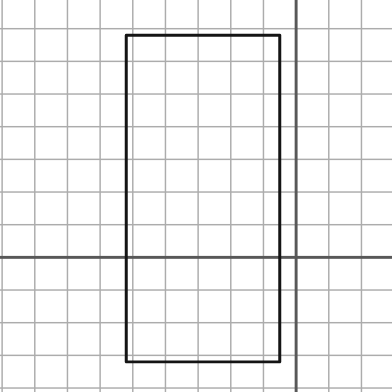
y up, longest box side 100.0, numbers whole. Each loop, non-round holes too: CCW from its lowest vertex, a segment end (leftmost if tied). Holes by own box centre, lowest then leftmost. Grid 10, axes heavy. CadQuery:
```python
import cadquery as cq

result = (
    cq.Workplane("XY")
    .moveTo(-52.0, -32.0)
    .lineTo(-5.0, -32.0)
    .lineTo(-5.0, 68.0)
    .lineTo(-52.0, 68.0)
    .close()
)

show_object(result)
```